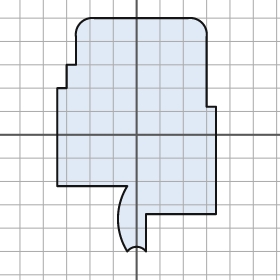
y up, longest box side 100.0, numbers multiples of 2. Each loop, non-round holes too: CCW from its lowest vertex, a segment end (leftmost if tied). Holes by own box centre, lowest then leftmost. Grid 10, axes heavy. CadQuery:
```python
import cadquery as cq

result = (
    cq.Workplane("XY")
    .moveTo(-4.0, -50.0)
    .threePointArc((0.0, -48.0), (4.0, -50.0))
    .lineTo(4.0, -34.0)
    .lineTo(34.0, -34.0)
    .lineTo(34.0, 12.0)
    .lineTo(30.0, 12.0)
    .lineTo(30.0, 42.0)
    .threePointArc((28.0, 48.0), (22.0, 50.0))
    .lineTo(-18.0, 50.0)
    .threePointArc((-24.0, 48.0), (-26.0, 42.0))
    .lineTo(-26.0, 30.0)
    .lineTo(-30.0, 30.0)
    .lineTo(-30.0, 20.0)
    .lineTo(-34.0, 20.0)
    .lineTo(-34.0, -22.0)
    .lineTo(-4.0, -22.0)
    .threePointArc((-8.0, -36.0), (-4.0, -50.0))
    .close()
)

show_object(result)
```